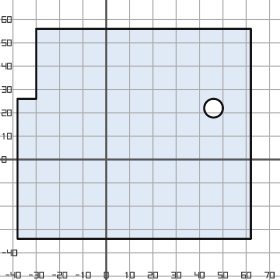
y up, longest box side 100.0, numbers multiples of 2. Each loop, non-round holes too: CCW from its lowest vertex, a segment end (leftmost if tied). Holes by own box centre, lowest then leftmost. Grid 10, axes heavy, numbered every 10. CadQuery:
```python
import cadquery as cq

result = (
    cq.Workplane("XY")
    .moveTo(-38.0, -34.0)
    .lineTo(62.0, -34.0)
    .lineTo(62.0, 56.0)
    .lineTo(-30.0, 56.0)
    .lineTo(-30.0, 26.0)
    .lineTo(-38.0, 26.0)
    .close()
    .moveTo(46.0, 22.0)
    .circle(4.0)
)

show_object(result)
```